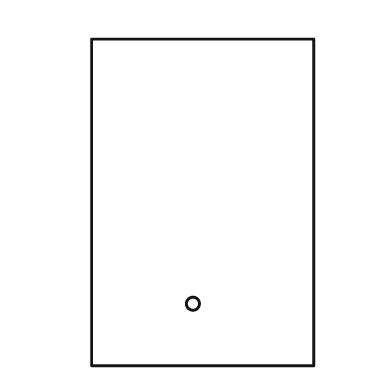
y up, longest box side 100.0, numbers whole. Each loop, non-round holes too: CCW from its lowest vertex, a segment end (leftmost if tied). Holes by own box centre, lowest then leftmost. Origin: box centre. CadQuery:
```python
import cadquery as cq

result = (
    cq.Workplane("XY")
    .moveTo(-34.0, -50.0)
    .lineTo(34.0, -50.0)
    .lineTo(34.0, 50.0)
    .lineTo(-34.0, 50.0)
    .close()
    .moveTo(-3.0, -31.0)
    .circle(2.0)
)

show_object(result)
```